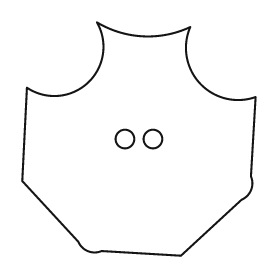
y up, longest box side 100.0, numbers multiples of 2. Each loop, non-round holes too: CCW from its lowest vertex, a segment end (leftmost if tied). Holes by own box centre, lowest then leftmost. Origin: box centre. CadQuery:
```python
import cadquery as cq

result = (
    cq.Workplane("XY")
    .moveTo(18.0, -50.0)
    .lineTo(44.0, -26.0)
    .threePointArc((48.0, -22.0), (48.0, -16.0))
    .lineTo(50.0, 18.0)
    .threePointArc((26.0, 24.0), (22.0, 48.0))
    .threePointArc((2.0, 44.0), (-18.0, 50.0))
    .threePointArc((-22.0, 24.0), (-48.0, 22.0))
    .lineTo(-50.0, -18.0)
    .lineTo(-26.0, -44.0)
    .threePointArc((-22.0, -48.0), (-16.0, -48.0))
    .close()
    .moveTo(-6.0, 0.0)
    .circle(4.0)
    .moveTo(6.0, 0.0)
    .circle(4.0)
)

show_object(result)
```